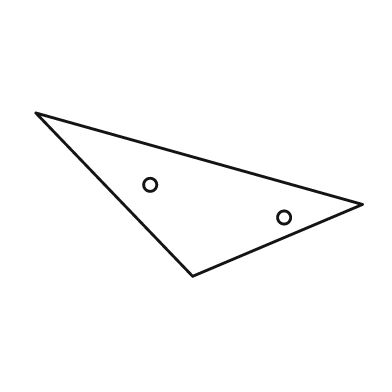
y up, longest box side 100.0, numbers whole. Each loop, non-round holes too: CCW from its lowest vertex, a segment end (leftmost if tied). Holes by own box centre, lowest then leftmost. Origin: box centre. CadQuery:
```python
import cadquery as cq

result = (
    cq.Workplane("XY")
    .moveTo(-2.0, -25.0)
    .lineTo(50.0, -3.0)
    .lineTo(-50.0, 25.0)
    .close()
    .moveTo(26.0, -7.0)
    .circle(2.0)
    .moveTo(-15.0, 3.0)
    .circle(2.0)
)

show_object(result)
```